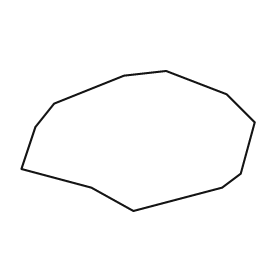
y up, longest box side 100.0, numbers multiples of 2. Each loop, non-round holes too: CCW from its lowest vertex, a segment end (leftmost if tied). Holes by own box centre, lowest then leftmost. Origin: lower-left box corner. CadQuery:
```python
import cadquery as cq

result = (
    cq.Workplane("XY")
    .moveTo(48.0, 0.0)
    .lineTo(86.0, 10.0)
    .lineTo(94.0, 16.0)
    .lineTo(100.0, 38.0)
    .lineTo(88.0, 50.0)
    .lineTo(62.0, 60.0)
    .lineTo(44.0, 58.0)
    .lineTo(14.0, 46.0)
    .lineTo(6.0, 36.0)
    .lineTo(0.0, 18.0)
    .lineTo(30.0, 10.0)
    .close()
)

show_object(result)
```